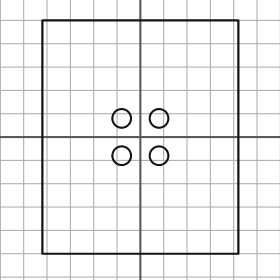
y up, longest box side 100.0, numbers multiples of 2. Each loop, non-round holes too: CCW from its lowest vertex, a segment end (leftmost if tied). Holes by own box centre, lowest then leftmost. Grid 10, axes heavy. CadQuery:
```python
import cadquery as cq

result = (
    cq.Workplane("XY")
    .moveTo(-42.0, -50.0)
    .lineTo(42.0, -50.0)
    .lineTo(42.0, 50.0)
    .lineTo(-42.0, 50.0)
    .close()
    .moveTo(-8.0, -8.0)
    .circle(4.0)
    .moveTo(8.0, -8.0)
    .circle(4.0)
    .moveTo(-8.0, 8.0)
    .circle(4.0)
    .moveTo(8.0, 8.0)
    .circle(4.0)
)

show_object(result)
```